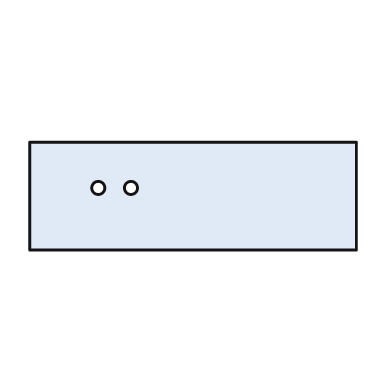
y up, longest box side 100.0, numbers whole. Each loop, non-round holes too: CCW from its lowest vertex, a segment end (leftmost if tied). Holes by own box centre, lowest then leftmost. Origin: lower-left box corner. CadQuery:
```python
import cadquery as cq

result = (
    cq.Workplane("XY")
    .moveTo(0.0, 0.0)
    .lineTo(100.0, 0.0)
    .lineTo(100.0, 33.0)
    .lineTo(0.0, 33.0)
    .close()
    .moveTo(21.0, 19.0)
    .circle(2.0)
    .moveTo(31.0, 19.0)
    .circle(2.0)
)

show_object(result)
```